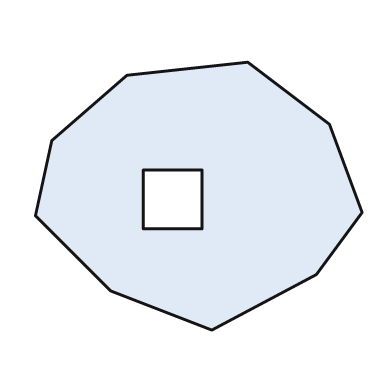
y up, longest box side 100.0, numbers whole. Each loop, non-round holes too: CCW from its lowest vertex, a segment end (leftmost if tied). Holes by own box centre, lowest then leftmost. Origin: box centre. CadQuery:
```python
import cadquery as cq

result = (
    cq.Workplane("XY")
    .moveTo(4.0, -41.0)
    .lineTo(36.0, -24.0)
    .lineTo(50.0, -5.0)
    .lineTo(40.0, 22.0)
    .lineTo(15.0, 41.0)
    .lineTo(-22.0, 37.0)
    .lineTo(-45.0, 17.0)
    .lineTo(-50.0, -6.0)
    .lineTo(-27.0, -29.0)
    .close()
    .moveTo(-17.0, -10.0)
    .lineTo(1.0, -10.0)
    .lineTo(1.0, 8.0)
    .lineTo(-17.0, 8.0)
    .close()
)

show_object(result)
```